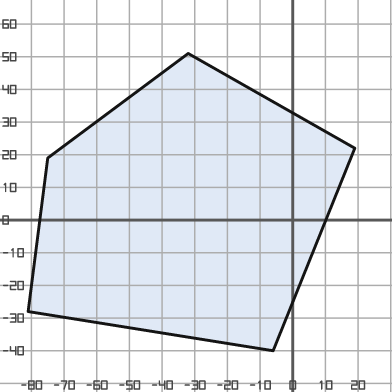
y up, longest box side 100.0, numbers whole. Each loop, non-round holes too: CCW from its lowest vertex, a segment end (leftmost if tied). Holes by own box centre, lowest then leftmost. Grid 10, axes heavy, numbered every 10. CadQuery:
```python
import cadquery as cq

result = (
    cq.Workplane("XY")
    .moveTo(-6.0, -40.0)
    .lineTo(19.0, 22.0)
    .lineTo(-32.0, 51.0)
    .lineTo(-75.0, 19.0)
    .lineTo(-81.0, -28.0)
    .close()
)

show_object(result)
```